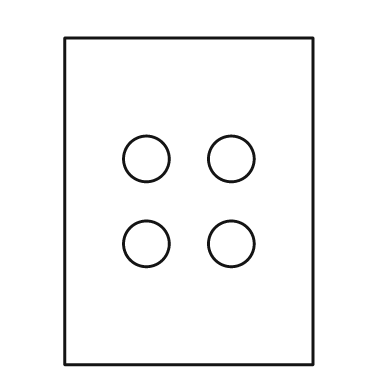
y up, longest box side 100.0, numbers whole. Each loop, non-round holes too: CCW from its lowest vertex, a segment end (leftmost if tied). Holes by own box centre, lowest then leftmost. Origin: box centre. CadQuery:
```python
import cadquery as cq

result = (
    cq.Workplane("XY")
    .moveTo(-38.0, -50.0)
    .lineTo(38.0, -50.0)
    .lineTo(38.0, 50.0)
    .lineTo(-38.0, 50.0)
    .close()
    .moveTo(-13.0, -13.0)
    .circle(7.0)
    .moveTo(13.0, -13.0)
    .circle(7.0)
    .moveTo(-13.0, 13.0)
    .circle(7.0)
    .moveTo(13.0, 13.0)
    .circle(7.0)
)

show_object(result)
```